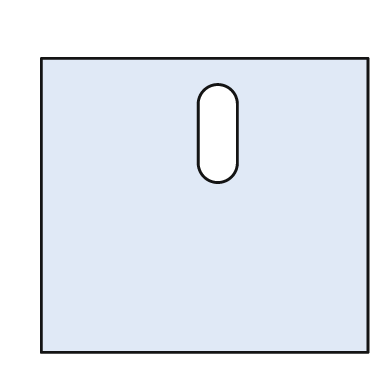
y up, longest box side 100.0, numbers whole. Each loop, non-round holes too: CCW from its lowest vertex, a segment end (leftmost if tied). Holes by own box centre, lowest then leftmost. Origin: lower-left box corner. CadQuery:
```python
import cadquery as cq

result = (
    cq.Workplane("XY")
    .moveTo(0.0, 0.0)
    .lineTo(100.0, 0.0)
    .lineTo(100.0, 90.0)
    .lineTo(0.0, 90.0)
    .close()
    .moveTo(48.0, 58.0)
    .threePointArc((54.0, 52.0), (60.0, 58.0))
    .lineTo(60.0, 76.0)
    .threePointArc((54.0, 82.0), (48.0, 76.0))
    .close()
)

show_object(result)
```